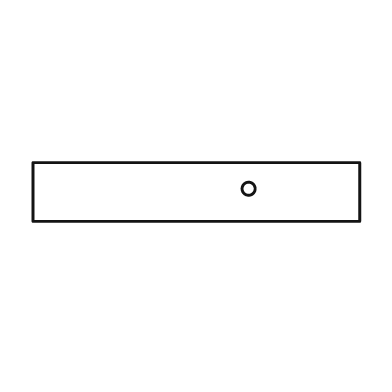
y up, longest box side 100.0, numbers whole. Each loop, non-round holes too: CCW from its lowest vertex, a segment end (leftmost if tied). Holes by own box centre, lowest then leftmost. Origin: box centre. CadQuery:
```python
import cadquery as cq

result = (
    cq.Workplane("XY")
    .moveTo(-50.0, -9.0)
    .lineTo(50.0, -9.0)
    .lineTo(50.0, 9.0)
    .lineTo(-50.0, 9.0)
    .close()
    .moveTo(16.0, 1.0)
    .circle(2.0)
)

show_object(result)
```